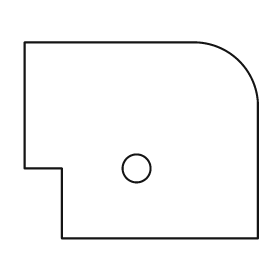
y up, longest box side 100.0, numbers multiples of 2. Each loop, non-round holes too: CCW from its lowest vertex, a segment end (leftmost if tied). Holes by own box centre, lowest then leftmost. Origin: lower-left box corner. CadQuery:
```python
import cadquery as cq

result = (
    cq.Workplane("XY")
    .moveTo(16.0, 0.0)
    .lineTo(100.0, 0.0)
    .lineTo(100.0, 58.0)
    .threePointArc((92.0, 76.0), (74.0, 84.0))
    .lineTo(0.0, 84.0)
    .lineTo(0.0, 30.0)
    .lineTo(16.0, 30.0)
    .close()
    .moveTo(48.0, 30.0)
    .circle(6.0)
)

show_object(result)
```